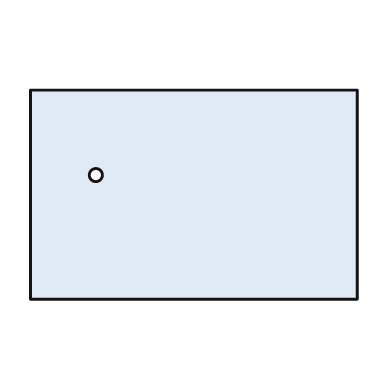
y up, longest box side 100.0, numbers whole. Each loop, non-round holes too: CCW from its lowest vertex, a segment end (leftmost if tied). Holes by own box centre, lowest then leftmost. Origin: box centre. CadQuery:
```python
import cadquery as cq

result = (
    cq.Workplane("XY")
    .moveTo(-50.0, -32.0)
    .lineTo(50.0, -32.0)
    .lineTo(50.0, 32.0)
    .lineTo(-50.0, 32.0)
    .close()
    .moveTo(-30.0, 6.0)
    .circle(2.0)
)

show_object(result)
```